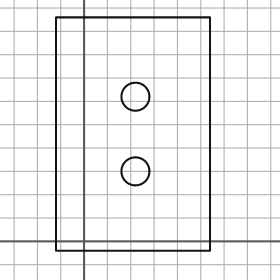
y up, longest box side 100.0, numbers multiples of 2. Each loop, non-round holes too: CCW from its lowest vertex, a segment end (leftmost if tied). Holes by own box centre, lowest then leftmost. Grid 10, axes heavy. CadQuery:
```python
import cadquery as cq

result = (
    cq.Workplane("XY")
    .moveTo(-12.0, -4.0)
    .lineTo(54.0, -4.0)
    .lineTo(54.0, 96.0)
    .lineTo(-12.0, 96.0)
    .close()
    .moveTo(22.0, 30.0)
    .circle(6.0)
    .moveTo(22.0, 62.0)
    .circle(6.0)
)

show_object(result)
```